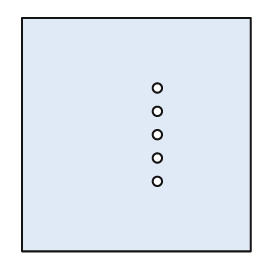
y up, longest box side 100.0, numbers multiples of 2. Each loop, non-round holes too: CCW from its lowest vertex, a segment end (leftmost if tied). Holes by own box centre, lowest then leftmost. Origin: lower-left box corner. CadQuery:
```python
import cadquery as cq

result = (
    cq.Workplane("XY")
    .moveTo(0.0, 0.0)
    .lineTo(98.0, 0.0)
    .lineTo(98.0, 100.0)
    .lineTo(0.0, 100.0)
    .close()
    .moveTo(58.0, 30.0)
    .circle(2.0)
    .moveTo(58.0, 40.0)
    .circle(2.0)
    .moveTo(58.0, 50.0)
    .circle(2.0)
    .moveTo(58.0, 60.0)
    .circle(2.0)
    .moveTo(58.0, 70.0)
    .circle(2.0)
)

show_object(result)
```